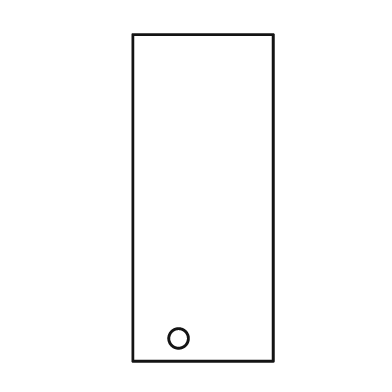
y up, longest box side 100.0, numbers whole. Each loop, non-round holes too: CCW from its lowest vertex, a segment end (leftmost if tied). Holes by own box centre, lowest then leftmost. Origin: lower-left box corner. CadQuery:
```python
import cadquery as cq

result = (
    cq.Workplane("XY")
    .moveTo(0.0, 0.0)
    .lineTo(43.0, 0.0)
    .lineTo(43.0, 100.0)
    .lineTo(0.0, 100.0)
    .close()
    .moveTo(14.0, 7.0)
    .circle(3.0)
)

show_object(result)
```